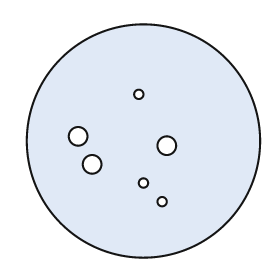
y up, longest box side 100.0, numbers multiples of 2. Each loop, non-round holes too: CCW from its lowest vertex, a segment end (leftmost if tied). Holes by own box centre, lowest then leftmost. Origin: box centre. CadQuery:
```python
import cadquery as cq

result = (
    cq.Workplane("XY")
    .moveTo(0.0, 0.0)
    .circle(50.0)
    .moveTo(8.0, -26.0)
    .circle(2.0)
    .moveTo(0.0, -18.0)
    .circle(2.0)
    .moveTo(-22.0, -10.0)
    .circle(4.0)
    .moveTo(10.0, -2.0)
    .circle(4.0)
    .moveTo(-28.0, 2.0)
    .circle(4.0)
    .moveTo(-2.0, 20.0)
    .circle(2.0)
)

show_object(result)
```